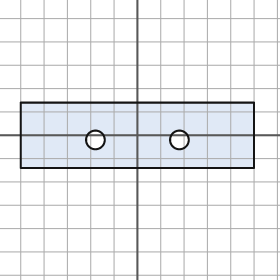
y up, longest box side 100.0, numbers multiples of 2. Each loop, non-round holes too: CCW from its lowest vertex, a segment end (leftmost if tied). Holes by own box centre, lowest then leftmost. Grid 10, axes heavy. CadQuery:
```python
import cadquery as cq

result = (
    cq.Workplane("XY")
    .moveTo(-50.0, -14.0)
    .lineTo(50.0, -14.0)
    .lineTo(50.0, 14.0)
    .lineTo(-50.0, 14.0)
    .close()
    .moveTo(-18.0, -2.0)
    .circle(4.0)
    .moveTo(18.0, -2.0)
    .circle(4.0)
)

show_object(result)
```